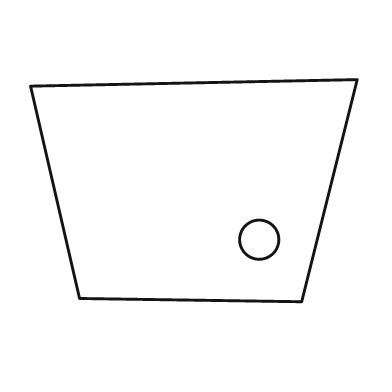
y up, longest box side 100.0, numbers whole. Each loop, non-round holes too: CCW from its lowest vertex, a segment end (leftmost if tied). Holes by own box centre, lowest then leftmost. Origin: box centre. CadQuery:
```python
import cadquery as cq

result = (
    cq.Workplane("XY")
    .moveTo(33.0, -34.0)
    .lineTo(50.0, 34.0)
    .lineTo(-50.0, 32.0)
    .lineTo(-35.0, -33.0)
    .close()
    .moveTo(20.0, -15.0)
    .circle(6.0)
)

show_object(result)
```